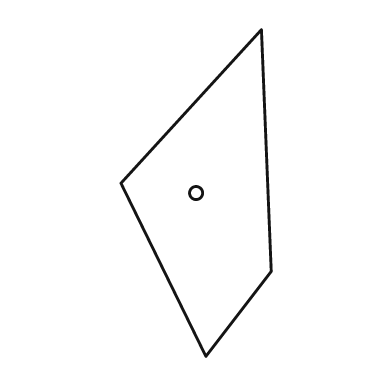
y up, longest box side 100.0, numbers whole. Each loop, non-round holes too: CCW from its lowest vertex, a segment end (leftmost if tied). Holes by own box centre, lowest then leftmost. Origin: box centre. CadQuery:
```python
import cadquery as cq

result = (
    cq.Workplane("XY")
    .moveTo(3.0, -50.0)
    .lineTo(23.0, -24.0)
    .lineTo(20.0, 50.0)
    .lineTo(-23.0, 3.0)
    .close()
    .moveTo(0.0, 0.0)
    .circle(2.0)
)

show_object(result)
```